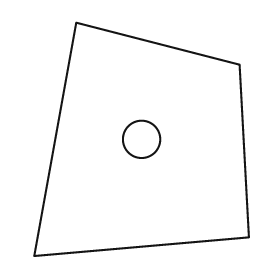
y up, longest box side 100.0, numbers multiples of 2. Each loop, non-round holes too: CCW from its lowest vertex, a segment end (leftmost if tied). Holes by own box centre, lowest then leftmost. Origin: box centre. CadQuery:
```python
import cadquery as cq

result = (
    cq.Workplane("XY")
    .moveTo(-46.0, -50.0)
    .lineTo(46.0, -42.0)
    .lineTo(42.0, 32.0)
    .lineTo(-28.0, 50.0)
    .close()
    .moveTo(0.0, 0.0)
    .circle(8.0)
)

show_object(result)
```